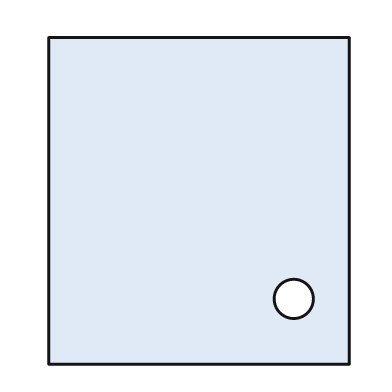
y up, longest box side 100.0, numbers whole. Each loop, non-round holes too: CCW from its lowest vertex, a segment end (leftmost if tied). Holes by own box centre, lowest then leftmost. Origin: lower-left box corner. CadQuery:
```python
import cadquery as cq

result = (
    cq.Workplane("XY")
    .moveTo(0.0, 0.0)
    .lineTo(92.0, 0.0)
    .lineTo(92.0, 100.0)
    .lineTo(0.0, 100.0)
    .close()
    .moveTo(75.0, 20.0)
    .circle(6.0)
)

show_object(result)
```